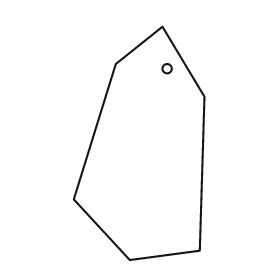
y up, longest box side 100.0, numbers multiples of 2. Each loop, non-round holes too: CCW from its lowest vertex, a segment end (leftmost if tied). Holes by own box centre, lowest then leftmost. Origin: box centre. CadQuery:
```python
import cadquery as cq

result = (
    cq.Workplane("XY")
    .moveTo(-4.0, -50.0)
    .lineTo(26.0, -46.0)
    .lineTo(28.0, 20.0)
    .lineTo(10.0, 50.0)
    .lineTo(-10.0, 34.0)
    .lineTo(-28.0, -24.0)
    .close()
    .moveTo(12.0, 32.0)
    .circle(2.0)
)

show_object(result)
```